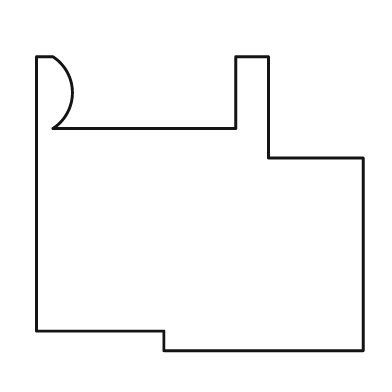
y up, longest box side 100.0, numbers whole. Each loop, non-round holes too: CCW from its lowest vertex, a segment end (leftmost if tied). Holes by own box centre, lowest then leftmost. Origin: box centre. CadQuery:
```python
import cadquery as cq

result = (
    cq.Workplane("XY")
    .moveTo(-11.0, -45.0)
    .lineTo(50.0, -45.0)
    .lineTo(50.0, 14.0)
    .lineTo(21.0, 14.0)
    .lineTo(21.0, 45.0)
    .lineTo(11.0, 45.0)
    .lineTo(11.0, 23.0)
    .lineTo(-45.0, 23.0)
    .threePointArc((-39.0, 34.0), (-45.0, 45.0))
    .lineTo(-50.0, 45.0)
    .lineTo(-50.0, -39.0)
    .lineTo(-11.0, -39.0)
    .close()
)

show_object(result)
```